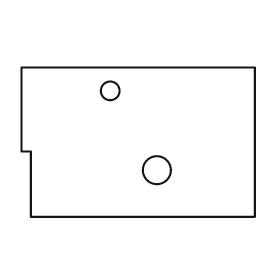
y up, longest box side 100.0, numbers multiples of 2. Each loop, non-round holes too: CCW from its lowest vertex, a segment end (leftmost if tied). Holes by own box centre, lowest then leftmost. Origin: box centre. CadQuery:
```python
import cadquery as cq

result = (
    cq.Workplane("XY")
    .moveTo(-46.0, -32.0)
    .lineTo(50.0, -32.0)
    .lineTo(50.0, 32.0)
    .lineTo(-50.0, 32.0)
    .lineTo(-50.0, -4.0)
    .lineTo(-46.0, -4.0)
    .close()
    .moveTo(8.0, -12.0)
    .circle(6.0)
    .moveTo(-12.0, 22.0)
    .circle(4.0)
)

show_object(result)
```